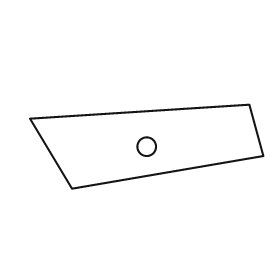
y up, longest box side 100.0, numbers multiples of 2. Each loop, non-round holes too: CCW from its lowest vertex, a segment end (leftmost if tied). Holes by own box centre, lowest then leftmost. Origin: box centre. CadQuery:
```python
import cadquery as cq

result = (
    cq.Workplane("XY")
    .moveTo(-32.0, -18.0)
    .lineTo(50.0, -4.0)
    .lineTo(44.0, 18.0)
    .lineTo(-50.0, 12.0)
    .close()
    .moveTo(0.0, 0.0)
    .circle(4.0)
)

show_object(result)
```